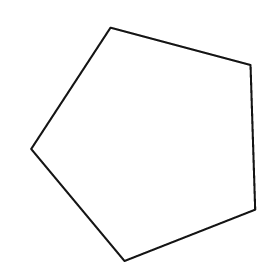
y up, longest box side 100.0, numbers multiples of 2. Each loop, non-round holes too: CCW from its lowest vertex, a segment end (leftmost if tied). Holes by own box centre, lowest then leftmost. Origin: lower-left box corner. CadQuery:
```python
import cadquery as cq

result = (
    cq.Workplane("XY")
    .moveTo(40.0, 0.0)
    .lineTo(96.0, 22.0)
    .lineTo(94.0, 84.0)
    .lineTo(34.0, 100.0)
    .lineTo(0.0, 48.0)
    .close()
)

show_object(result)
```